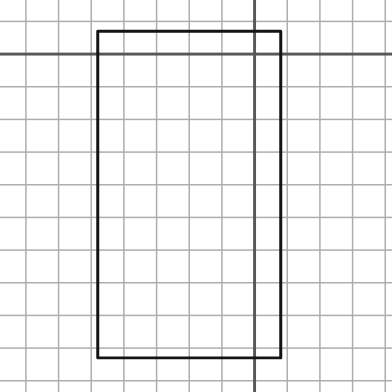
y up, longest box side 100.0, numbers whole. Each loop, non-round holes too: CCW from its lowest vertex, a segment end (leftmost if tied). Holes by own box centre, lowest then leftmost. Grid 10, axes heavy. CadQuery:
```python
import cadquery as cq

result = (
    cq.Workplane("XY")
    .moveTo(-48.0, -93.0)
    .lineTo(8.0, -93.0)
    .lineTo(8.0, 7.0)
    .lineTo(-48.0, 7.0)
    .close()
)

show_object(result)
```